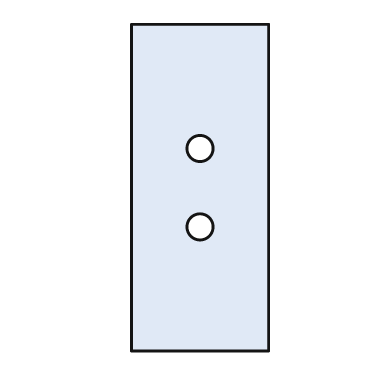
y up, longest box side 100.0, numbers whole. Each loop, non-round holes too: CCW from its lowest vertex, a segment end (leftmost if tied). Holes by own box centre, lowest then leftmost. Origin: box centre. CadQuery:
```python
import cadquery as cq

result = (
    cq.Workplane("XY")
    .moveTo(-21.0, -50.0)
    .lineTo(21.0, -50.0)
    .lineTo(21.0, 50.0)
    .lineTo(-21.0, 50.0)
    .close()
    .moveTo(0.0, -12.0)
    .circle(4.0)
    .moveTo(0.0, 12.0)
    .circle(4.0)
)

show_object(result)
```